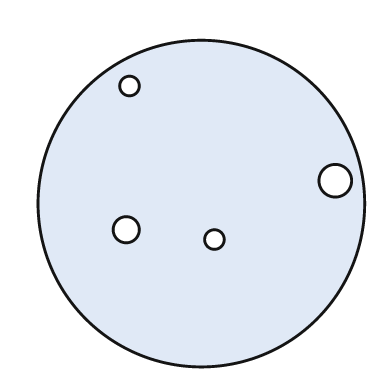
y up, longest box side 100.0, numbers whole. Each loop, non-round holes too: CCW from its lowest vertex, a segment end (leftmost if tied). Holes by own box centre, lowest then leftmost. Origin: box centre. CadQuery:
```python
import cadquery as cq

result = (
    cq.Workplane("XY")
    .moveTo(0.0, 0.0)
    .circle(50.0)
    .moveTo(4.0, -11.0)
    .circle(3.0)
    .moveTo(-23.0, -8.0)
    .circle(4.0)
    .moveTo(41.0, 7.0)
    .circle(5.0)
    .moveTo(-22.0, 36.0)
    .circle(3.0)
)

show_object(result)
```